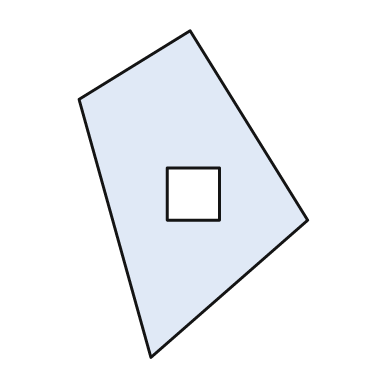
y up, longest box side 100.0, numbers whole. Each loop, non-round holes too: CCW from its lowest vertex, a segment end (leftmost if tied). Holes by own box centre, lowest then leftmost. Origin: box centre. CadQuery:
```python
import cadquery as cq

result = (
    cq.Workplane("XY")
    .moveTo(-13.0, -50.0)
    .lineTo(35.0, -8.0)
    .lineTo(-1.0, 50.0)
    .lineTo(-35.0, 29.0)
    .close()
    .moveTo(-8.0, -8.0)
    .lineTo(8.0, -8.0)
    .lineTo(8.0, 8.0)
    .lineTo(-8.0, 8.0)
    .close()
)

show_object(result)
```